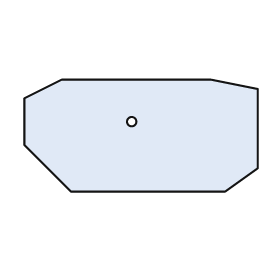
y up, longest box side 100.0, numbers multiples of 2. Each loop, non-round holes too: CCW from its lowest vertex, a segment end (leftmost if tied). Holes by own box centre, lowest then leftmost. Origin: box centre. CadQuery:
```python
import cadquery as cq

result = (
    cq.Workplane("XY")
    .moveTo(-30.0, -24.0)
    .lineTo(36.0, -24.0)
    .lineTo(50.0, -14.0)
    .lineTo(50.0, 20.0)
    .lineTo(30.0, 24.0)
    .lineTo(-34.0, 24.0)
    .lineTo(-50.0, 16.0)
    .lineTo(-50.0, -4.0)
    .close()
    .moveTo(-4.0, 6.0)
    .circle(2.0)
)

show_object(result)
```